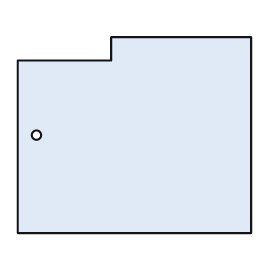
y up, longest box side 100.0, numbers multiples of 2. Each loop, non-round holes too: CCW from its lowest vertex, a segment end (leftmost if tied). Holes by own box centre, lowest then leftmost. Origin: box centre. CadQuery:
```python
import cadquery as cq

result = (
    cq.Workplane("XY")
    .moveTo(-50.0, -42.0)
    .lineTo(50.0, -42.0)
    .lineTo(50.0, 42.0)
    .lineTo(-10.0, 42.0)
    .lineTo(-10.0, 32.0)
    .lineTo(-50.0, 32.0)
    .close()
    .moveTo(-42.0, 0.0)
    .circle(2.0)
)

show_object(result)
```